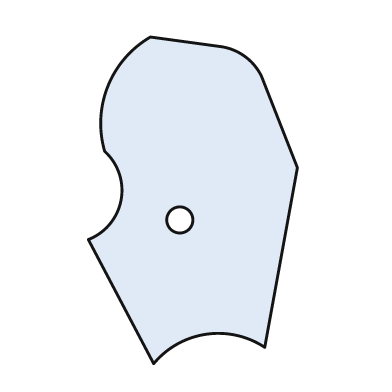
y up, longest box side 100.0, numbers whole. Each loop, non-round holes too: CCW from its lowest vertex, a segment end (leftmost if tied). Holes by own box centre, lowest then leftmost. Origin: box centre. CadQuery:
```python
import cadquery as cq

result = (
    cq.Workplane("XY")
    .moveTo(-12.0, -50.0)
    .threePointArc((4.0, -41.0), (22.0, -45.0))
    .lineTo(32.0, 10.0)
    .lineTo(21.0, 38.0)
    .threePointArc((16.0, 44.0), (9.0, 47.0))
    .lineTo(-13.0, 50.0)
    .threePointArc((-26.0, 35.0), (-27.0, 15.0))
    .threePointArc((-22.0, 0.0), (-32.0, -12.0))
    .close()
    .moveTo(-4.0, -6.0)
    .circle(4.0)
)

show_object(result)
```